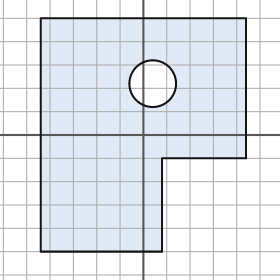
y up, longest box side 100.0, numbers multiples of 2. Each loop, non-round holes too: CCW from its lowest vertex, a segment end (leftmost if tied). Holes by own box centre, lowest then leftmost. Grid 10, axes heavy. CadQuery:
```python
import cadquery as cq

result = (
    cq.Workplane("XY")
    .moveTo(-44.0, -50.0)
    .lineTo(8.0, -50.0)
    .lineTo(8.0, -10.0)
    .lineTo(44.0, -10.0)
    .lineTo(44.0, 50.0)
    .lineTo(-44.0, 50.0)
    .close()
    .moveTo(4.0, 22.0)
    .circle(10.0)
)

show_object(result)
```